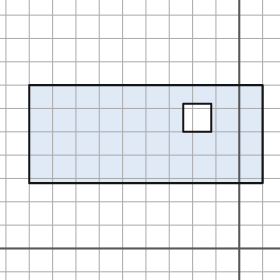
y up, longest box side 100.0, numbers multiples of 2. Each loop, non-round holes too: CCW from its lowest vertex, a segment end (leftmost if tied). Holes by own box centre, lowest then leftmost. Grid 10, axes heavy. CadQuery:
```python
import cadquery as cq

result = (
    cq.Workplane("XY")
    .moveTo(-90.0, 28.0)
    .lineTo(10.0, 28.0)
    .lineTo(10.0, 70.0)
    .lineTo(-90.0, 70.0)
    .close()
    .moveTo(-24.0, 50.0)
    .lineTo(-12.0, 50.0)
    .lineTo(-12.0, 62.0)
    .lineTo(-24.0, 62.0)
    .close()
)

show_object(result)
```